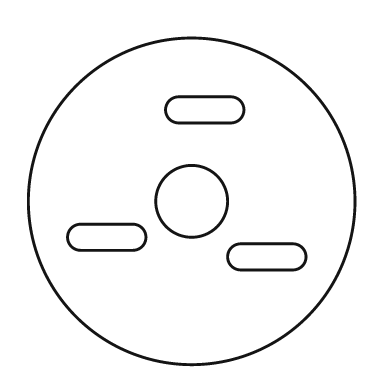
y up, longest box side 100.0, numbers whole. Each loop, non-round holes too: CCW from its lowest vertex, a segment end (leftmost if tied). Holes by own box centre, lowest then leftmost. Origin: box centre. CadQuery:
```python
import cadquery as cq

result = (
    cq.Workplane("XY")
    .moveTo(0.0, 0.0)
    .circle(50.0)
    .moveTo(15.0, -21.0)
    .lineTo(31.0, -21.0)
    .threePointArc((35.0, -17.0), (31.0, -13.0))
    .lineTo(15.0, -13.0)
    .threePointArc((11.0, -17.0), (15.0, -21.0))
    .close()
    .moveTo(-34.0, -15.0)
    .lineTo(-18.0, -15.0)
    .threePointArc((-14.0, -11.0), (-18.0, -7.0))
    .lineTo(-34.0, -7.0)
    .threePointArc((-38.0, -11.0), (-34.0, -15.0))
    .close()
    .moveTo(0.0, 0.0)
    .circle(11.0)
    .moveTo(-4.0, 24.0)
    .lineTo(12.0, 24.0)
    .threePointArc((16.0, 28.0), (12.0, 32.0))
    .lineTo(-4.0, 32.0)
    .threePointArc((-8.0, 28.0), (-4.0, 24.0))
    .close()
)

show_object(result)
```